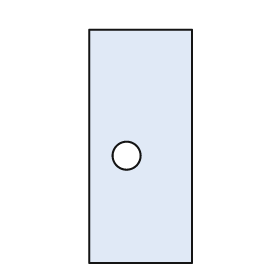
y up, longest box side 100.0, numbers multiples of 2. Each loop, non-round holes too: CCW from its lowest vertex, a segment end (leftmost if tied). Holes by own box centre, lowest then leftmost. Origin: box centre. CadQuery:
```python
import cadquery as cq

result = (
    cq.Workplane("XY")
    .moveTo(-22.0, -50.0)
    .lineTo(22.0, -50.0)
    .lineTo(22.0, 50.0)
    .lineTo(-22.0, 50.0)
    .close()
    .moveTo(-6.0, -4.0)
    .circle(6.0)
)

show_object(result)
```